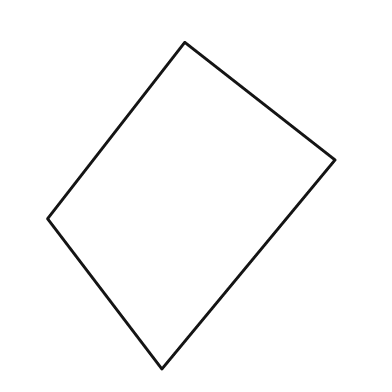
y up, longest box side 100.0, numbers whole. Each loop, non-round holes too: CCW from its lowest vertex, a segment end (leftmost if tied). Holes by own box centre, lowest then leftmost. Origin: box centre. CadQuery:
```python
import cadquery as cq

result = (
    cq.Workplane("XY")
    .moveTo(-9.0, -50.0)
    .lineTo(44.0, 14.0)
    .lineTo(-2.0, 50.0)
    .lineTo(-44.0, -4.0)
    .close()
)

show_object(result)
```